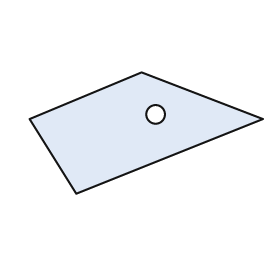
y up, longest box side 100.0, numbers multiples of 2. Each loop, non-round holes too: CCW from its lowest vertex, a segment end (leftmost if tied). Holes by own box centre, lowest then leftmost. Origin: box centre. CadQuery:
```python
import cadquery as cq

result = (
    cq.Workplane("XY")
    .moveTo(-30.0, -26.0)
    .lineTo(50.0, 6.0)
    .lineTo(-2.0, 26.0)
    .lineTo(-50.0, 6.0)
    .close()
    .moveTo(4.0, 8.0)
    .circle(4.0)
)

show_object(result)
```